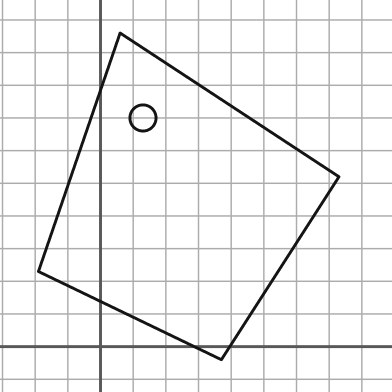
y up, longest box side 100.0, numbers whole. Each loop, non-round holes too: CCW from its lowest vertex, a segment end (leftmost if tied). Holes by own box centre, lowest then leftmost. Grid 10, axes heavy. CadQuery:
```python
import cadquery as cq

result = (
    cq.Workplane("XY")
    .moveTo(37.0, -4.0)
    .lineTo(73.0, 52.0)
    .lineTo(6.0, 96.0)
    .lineTo(-19.0, 23.0)
    .close()
    .moveTo(13.0, 70.0)
    .circle(4.0)
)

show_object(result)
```